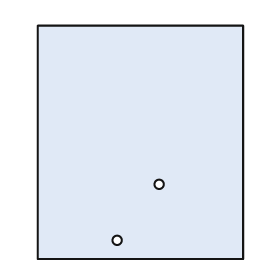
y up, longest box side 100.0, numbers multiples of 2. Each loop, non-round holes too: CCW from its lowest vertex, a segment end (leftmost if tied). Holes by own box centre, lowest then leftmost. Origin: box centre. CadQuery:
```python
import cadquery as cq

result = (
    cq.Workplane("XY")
    .moveTo(-44.0, -50.0)
    .lineTo(44.0, -50.0)
    .lineTo(44.0, 50.0)
    .lineTo(-44.0, 50.0)
    .close()
    .moveTo(-10.0, -42.0)
    .circle(2.0)
    .moveTo(8.0, -18.0)
    .circle(2.0)
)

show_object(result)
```